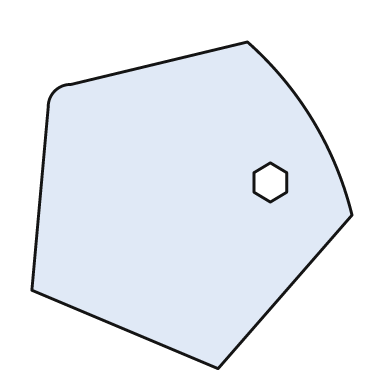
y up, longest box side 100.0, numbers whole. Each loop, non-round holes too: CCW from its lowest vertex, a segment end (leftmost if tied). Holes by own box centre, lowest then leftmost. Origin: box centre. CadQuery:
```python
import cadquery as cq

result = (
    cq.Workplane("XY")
    .moveTo(8.0, -50.0)
    .lineTo(49.0, -3.0)
    .threePointArc((37.0, 26.0), (17.0, 50.0))
    .lineTo(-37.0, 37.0)
    .threePointArc((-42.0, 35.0), (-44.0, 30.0))
    .lineTo(-49.0, -26.0)
    .close()
    .moveTo(24.0, 1.0)
    .lineTo(29.0, 4.0)
    .lineTo(29.0, 10.0)
    .lineTo(24.0, 13.0)
    .lineTo(19.0, 10.0)
    .lineTo(19.0, 4.0)
    .close()
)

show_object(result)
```